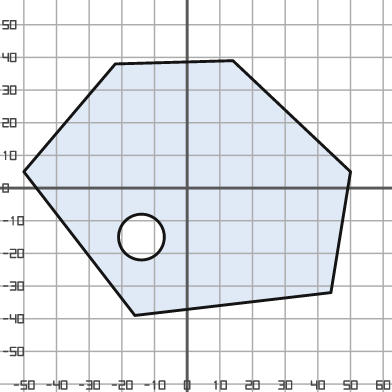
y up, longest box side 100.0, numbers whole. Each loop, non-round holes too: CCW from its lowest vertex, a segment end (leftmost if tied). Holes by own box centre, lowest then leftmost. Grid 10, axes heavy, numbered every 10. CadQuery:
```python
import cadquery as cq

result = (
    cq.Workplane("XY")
    .moveTo(-16.0, -39.0)
    .lineTo(44.0, -32.0)
    .lineTo(50.0, 5.0)
    .lineTo(14.0, 39.0)
    .lineTo(-22.0, 38.0)
    .lineTo(-50.0, 5.0)
    .close()
    .moveTo(-14.0, -15.0)
    .circle(7.0)
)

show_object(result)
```